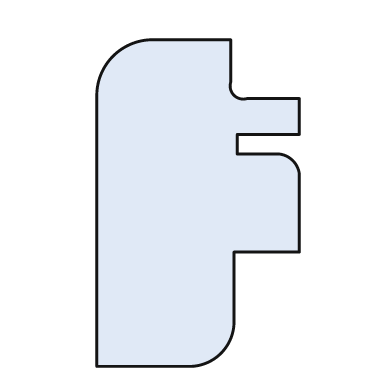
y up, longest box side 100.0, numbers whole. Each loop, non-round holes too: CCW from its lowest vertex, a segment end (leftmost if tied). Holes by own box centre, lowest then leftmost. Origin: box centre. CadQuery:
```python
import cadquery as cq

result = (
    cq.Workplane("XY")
    .moveTo(-31.0, -50.0)
    .lineTo(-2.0, -50.0)
    .threePointArc((7.0, -46.0), (11.0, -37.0))
    .lineTo(11.0, -15.0)
    .lineTo(31.0, -15.0)
    .lineTo(31.0, 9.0)
    .threePointArc((29.0, 13.0), (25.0, 15.0))
    .lineTo(12.0, 15.0)
    .lineTo(12.0, 21.0)
    .lineTo(31.0, 21.0)
    .lineTo(31.0, 32.0)
    .lineTo(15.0, 32.0)
    .threePointArc((11.0, 33.0), (10.0, 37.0))
    .lineTo(10.0, 50.0)
    .lineTo(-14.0, 50.0)
    .threePointArc((-26.0, 45.0), (-31.0, 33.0))
    .close()
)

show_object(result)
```